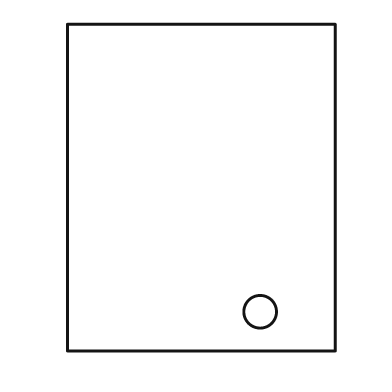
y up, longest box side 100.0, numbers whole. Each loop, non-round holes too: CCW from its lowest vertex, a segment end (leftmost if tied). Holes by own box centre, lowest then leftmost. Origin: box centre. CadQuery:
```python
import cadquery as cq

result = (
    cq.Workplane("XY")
    .moveTo(-41.0, -50.0)
    .lineTo(41.0, -50.0)
    .lineTo(41.0, 50.0)
    .lineTo(-41.0, 50.0)
    .close()
    .moveTo(18.0, -38.0)
    .circle(5.0)
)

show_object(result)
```